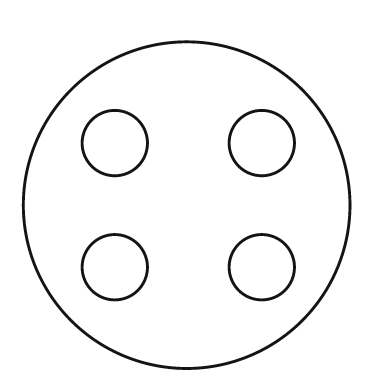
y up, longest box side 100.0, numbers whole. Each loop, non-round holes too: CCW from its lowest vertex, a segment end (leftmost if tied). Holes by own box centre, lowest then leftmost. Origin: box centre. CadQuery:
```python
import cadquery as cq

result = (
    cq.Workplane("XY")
    .moveTo(0.0, 0.0)
    .circle(50.0)
    .moveTo(-22.0, -19.0)
    .circle(10.0)
    .moveTo(23.0, -19.0)
    .circle(10.0)
    .moveTo(-22.0, 19.0)
    .circle(10.0)
    .moveTo(23.0, 19.0)
    .circle(10.0)
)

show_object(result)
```